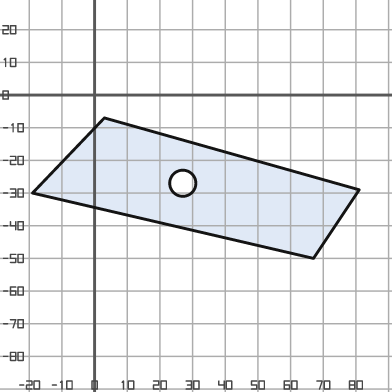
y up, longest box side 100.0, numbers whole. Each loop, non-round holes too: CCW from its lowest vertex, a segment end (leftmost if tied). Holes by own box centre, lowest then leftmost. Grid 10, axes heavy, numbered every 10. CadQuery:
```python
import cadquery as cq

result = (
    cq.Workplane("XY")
    .moveTo(67.0, -50.0)
    .lineTo(81.0, -29.0)
    .lineTo(3.0, -7.0)
    .lineTo(-19.0, -30.0)
    .close()
    .moveTo(27.0, -27.0)
    .circle(4.0)
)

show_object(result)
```